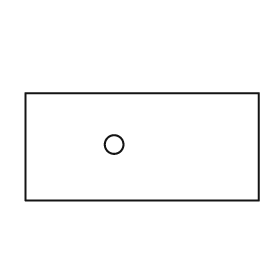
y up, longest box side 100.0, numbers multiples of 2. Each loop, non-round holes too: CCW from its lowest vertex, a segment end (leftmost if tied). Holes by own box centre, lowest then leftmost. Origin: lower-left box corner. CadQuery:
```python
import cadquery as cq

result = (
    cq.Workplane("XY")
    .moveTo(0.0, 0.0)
    .lineTo(100.0, 0.0)
    .lineTo(100.0, 46.0)
    .lineTo(0.0, 46.0)
    .close()
    .moveTo(38.0, 24.0)
    .circle(4.0)
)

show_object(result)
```